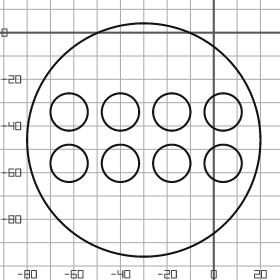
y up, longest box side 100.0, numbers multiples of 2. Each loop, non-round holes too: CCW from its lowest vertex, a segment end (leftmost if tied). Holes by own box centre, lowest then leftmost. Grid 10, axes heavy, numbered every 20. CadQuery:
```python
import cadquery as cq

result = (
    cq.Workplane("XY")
    .moveTo(-30.0, -46.0)
    .circle(50.0)
    .moveTo(-62.0, -56.0)
    .circle(8.0)
    .moveTo(-40.0, -56.0)
    .circle(8.0)
    .moveTo(-18.0, -56.0)
    .circle(8.0)
    .moveTo(4.0, -56.0)
    .circle(8.0)
    .moveTo(-62.0, -34.0)
    .circle(8.0)
    .moveTo(-40.0, -34.0)
    .circle(8.0)
    .moveTo(-18.0, -34.0)
    .circle(8.0)
    .moveTo(4.0, -34.0)
    .circle(8.0)
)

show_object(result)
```